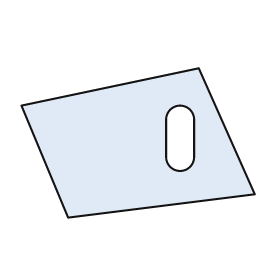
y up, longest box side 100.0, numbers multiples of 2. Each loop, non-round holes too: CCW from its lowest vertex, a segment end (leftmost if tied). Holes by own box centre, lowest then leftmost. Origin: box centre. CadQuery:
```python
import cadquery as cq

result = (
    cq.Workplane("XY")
    .moveTo(-30.0, -32.0)
    .lineTo(50.0, -22.0)
    .lineTo(26.0, 32.0)
    .lineTo(-50.0, 16.0)
    .close()
    .moveTo(12.0, -6.0)
    .threePointArc((18.0, -12.0), (24.0, -6.0))
    .lineTo(24.0, 10.0)
    .threePointArc((18.0, 16.0), (12.0, 10.0))
    .close()
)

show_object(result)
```